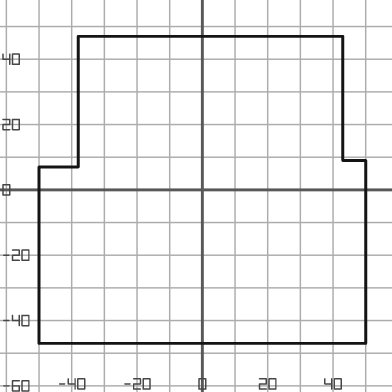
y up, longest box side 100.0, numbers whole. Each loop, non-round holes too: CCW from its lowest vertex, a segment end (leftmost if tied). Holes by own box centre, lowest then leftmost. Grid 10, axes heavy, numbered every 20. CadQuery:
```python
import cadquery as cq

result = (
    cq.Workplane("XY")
    .moveTo(-50.0, -47.0)
    .lineTo(50.0, -47.0)
    .lineTo(50.0, 9.0)
    .lineTo(43.0, 9.0)
    .lineTo(43.0, 47.0)
    .lineTo(-38.0, 47.0)
    .lineTo(-38.0, 7.0)
    .lineTo(-50.0, 7.0)
    .close()
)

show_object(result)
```